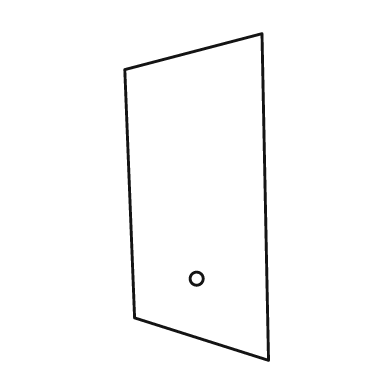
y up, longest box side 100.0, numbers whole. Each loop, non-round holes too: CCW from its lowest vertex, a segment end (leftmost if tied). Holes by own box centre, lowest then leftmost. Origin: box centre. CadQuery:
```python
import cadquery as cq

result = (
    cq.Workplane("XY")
    .moveTo(22.0, -50.0)
    .lineTo(20.0, 50.0)
    .lineTo(-22.0, 39.0)
    .lineTo(-19.0, -37.0)
    .close()
    .moveTo(0.0, -25.0)
    .circle(2.0)
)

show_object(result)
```